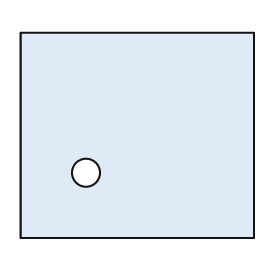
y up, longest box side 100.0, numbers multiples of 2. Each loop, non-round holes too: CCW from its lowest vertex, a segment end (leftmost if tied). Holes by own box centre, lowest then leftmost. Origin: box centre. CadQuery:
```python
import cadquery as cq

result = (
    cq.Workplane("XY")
    .moveTo(-50.0, -44.0)
    .lineTo(50.0, -44.0)
    .lineTo(50.0, 44.0)
    .lineTo(-50.0, 44.0)
    .close()
    .moveTo(-22.0, -16.0)
    .circle(6.0)
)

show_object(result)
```